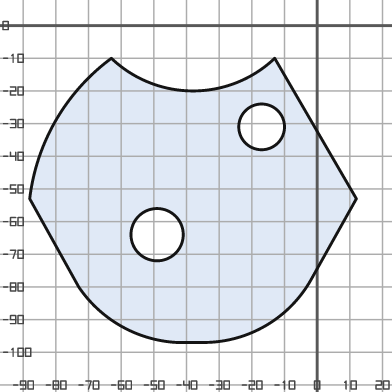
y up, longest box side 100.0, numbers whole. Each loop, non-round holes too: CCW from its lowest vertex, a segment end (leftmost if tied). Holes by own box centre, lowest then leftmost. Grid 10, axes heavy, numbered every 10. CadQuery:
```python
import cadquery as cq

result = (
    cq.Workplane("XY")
    .moveTo(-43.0, -97.0)
    .lineTo(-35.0, -97.0)
    .threePointArc((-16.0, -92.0), (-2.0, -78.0))
    .lineTo(12.0, -53.0)
    .lineTo(-13.0, -10.0)
    .threePointArc((-38.0, -20.0), (-63.0, -10.0))
    .threePointArc((-80.0, -29.0), (-88.0, -53.0))
    .lineTo(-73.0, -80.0)
    .threePointArc((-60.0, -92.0), (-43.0, -97.0))
    .close()
    .moveTo(-49.0, -64.0)
    .circle(8.0)
    .moveTo(-17.0, -31.0)
    .circle(7.0)
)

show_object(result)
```